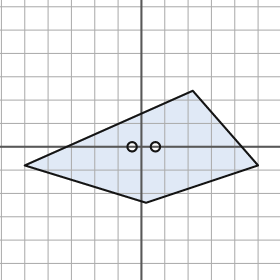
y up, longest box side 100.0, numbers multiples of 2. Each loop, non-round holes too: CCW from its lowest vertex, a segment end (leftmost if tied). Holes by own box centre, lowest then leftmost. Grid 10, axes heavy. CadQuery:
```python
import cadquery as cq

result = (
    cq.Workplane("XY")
    .moveTo(2.0, -24.0)
    .lineTo(50.0, -8.0)
    .lineTo(22.0, 24.0)
    .lineTo(-50.0, -8.0)
    .close()
    .moveTo(-4.0, 0.0)
    .circle(2.0)
    .moveTo(6.0, 0.0)
    .circle(2.0)
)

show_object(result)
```